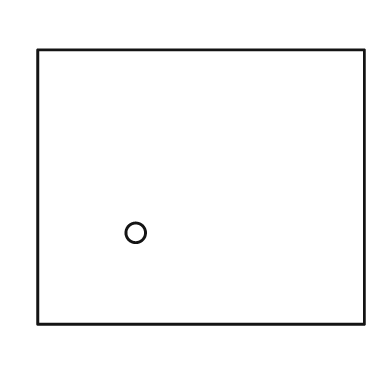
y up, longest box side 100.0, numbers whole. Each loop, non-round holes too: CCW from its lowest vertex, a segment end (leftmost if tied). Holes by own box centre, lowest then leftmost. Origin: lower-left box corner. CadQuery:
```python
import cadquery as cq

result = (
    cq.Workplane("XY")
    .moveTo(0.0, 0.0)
    .lineTo(100.0, 0.0)
    .lineTo(100.0, 84.0)
    .lineTo(0.0, 84.0)
    .close()
    .moveTo(30.0, 28.0)
    .circle(3.0)
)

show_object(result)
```